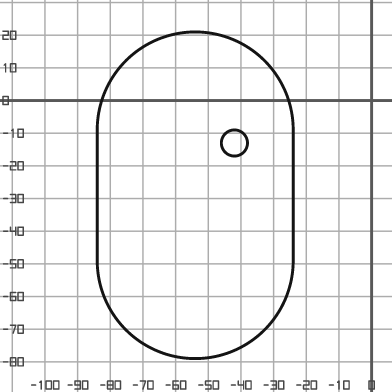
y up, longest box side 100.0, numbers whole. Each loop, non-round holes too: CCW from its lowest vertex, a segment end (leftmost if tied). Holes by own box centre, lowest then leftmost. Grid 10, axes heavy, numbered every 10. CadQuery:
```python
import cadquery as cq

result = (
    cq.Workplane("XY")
    .moveTo(-84.0, -49.0)
    .threePointArc((-54.0, -79.0), (-24.0, -49.0))
    .lineTo(-24.0, -9.0)
    .threePointArc((-54.0, 21.0), (-84.0, -9.0))
    .close()
    .moveTo(-42.0, -13.0)
    .circle(4.0)
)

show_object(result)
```